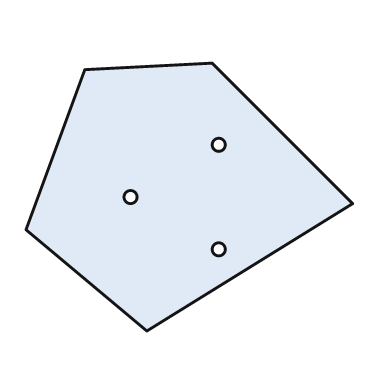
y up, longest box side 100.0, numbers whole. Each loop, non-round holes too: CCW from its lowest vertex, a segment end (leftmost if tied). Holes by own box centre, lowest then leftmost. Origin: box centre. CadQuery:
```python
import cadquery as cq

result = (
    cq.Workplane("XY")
    .moveTo(-13.0, -41.0)
    .lineTo(50.0, -2.0)
    .lineTo(7.0, 41.0)
    .lineTo(-32.0, 39.0)
    .lineTo(-50.0, -10.0)
    .close()
    .moveTo(9.0, -16.0)
    .circle(2.0)
    .moveTo(-18.0, 0.0)
    .circle(2.0)
    .moveTo(9.0, 16.0)
    .circle(2.0)
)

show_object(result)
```